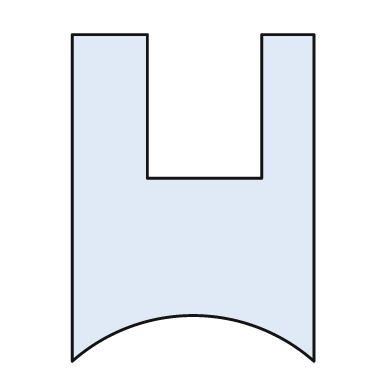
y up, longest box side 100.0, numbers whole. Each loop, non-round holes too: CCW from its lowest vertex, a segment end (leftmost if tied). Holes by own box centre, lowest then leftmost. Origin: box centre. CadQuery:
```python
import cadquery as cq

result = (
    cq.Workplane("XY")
    .moveTo(-37.0, -50.0)
    .threePointArc((0.0, -36.0), (37.0, -50.0))
    .lineTo(37.0, 50.0)
    .lineTo(21.0, 50.0)
    .lineTo(21.0, 6.0)
    .lineTo(-14.0, 6.0)
    .lineTo(-14.0, 50.0)
    .lineTo(-37.0, 50.0)
    .close()
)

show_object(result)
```